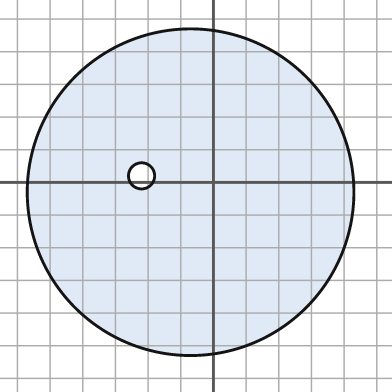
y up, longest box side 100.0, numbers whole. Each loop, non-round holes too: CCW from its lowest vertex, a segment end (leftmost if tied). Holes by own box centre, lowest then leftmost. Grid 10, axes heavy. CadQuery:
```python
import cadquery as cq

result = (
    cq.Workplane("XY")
    .moveTo(-7.0, -3.0)
    .circle(50.0)
    .moveTo(-22.0, 2.0)
    .circle(4.0)
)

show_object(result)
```